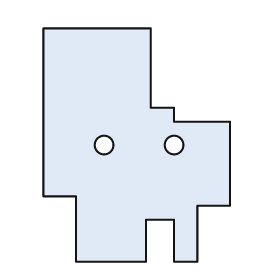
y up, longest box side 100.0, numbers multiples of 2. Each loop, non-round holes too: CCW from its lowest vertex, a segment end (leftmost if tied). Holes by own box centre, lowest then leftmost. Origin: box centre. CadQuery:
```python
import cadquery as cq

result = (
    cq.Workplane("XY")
    .moveTo(-26.0, -50.0)
    .lineTo(4.0, -50.0)
    .lineTo(4.0, -32.0)
    .lineTo(16.0, -32.0)
    .lineTo(16.0, -50.0)
    .lineTo(26.0, -50.0)
    .lineTo(26.0, -26.0)
    .lineTo(40.0, -26.0)
    .lineTo(40.0, 10.0)
    .lineTo(16.0, 10.0)
    .lineTo(16.0, 16.0)
    .lineTo(6.0, 16.0)
    .lineTo(6.0, 50.0)
    .lineTo(-40.0, 50.0)
    .lineTo(-40.0, -22.0)
    .lineTo(-26.0, -22.0)
    .close()
    .moveTo(-14.0, 0.0)
    .circle(4.0)
    .moveTo(16.0, 0.0)
    .circle(4.0)
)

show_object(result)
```